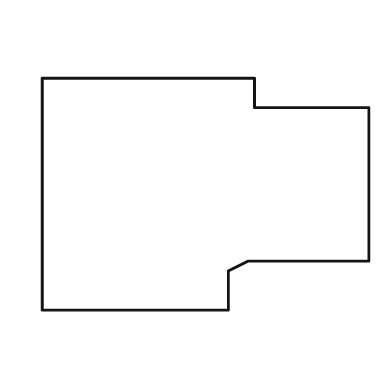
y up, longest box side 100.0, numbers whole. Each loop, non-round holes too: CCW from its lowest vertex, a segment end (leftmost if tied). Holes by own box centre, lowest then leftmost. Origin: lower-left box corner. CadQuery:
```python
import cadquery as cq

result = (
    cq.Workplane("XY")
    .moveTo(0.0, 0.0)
    .lineTo(57.0, 0.0)
    .lineTo(57.0, 12.0)
    .lineTo(63.0, 15.0)
    .lineTo(100.0, 15.0)
    .lineTo(100.0, 62.0)
    .lineTo(65.0, 62.0)
    .lineTo(65.0, 71.0)
    .lineTo(0.0, 71.0)
    .close()
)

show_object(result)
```